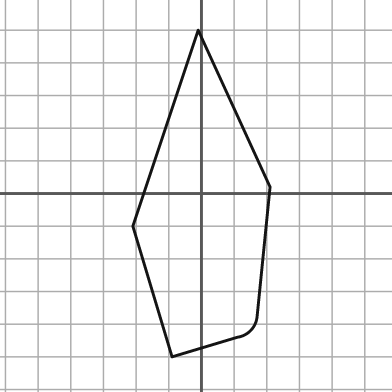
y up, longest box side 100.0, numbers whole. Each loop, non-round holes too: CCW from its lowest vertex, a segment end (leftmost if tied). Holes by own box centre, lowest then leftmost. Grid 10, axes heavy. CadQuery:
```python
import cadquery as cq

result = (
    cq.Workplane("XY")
    .moveTo(-9.0, -50.0)
    .lineTo(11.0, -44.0)
    .threePointArc((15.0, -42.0), (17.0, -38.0))
    .lineTo(21.0, 2.0)
    .lineTo(-1.0, 50.0)
    .lineTo(-21.0, -10.0)
    .close()
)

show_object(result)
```